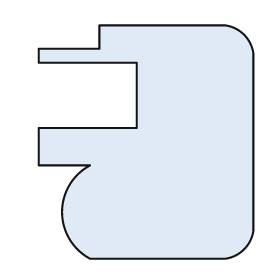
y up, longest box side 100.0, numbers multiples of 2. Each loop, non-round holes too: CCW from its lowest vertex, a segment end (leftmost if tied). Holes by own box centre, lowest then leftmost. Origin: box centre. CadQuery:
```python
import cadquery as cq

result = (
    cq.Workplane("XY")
    .moveTo(-24.0, -50.0)
    .lineTo(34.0, -50.0)
    .threePointArc((42.0, -46.0), (46.0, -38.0))
    .lineTo(46.0, 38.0)
    .threePointArc((42.0, 46.0), (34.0, 50.0))
    .lineTo(-20.0, 50.0)
    .lineTo(-20.0, 40.0)
    .lineTo(-46.0, 40.0)
    .lineTo(-46.0, 34.0)
    .lineTo(-4.0, 34.0)
    .lineTo(-4.0, 6.0)
    .lineTo(-46.0, 6.0)
    .lineTo(-46.0, -10.0)
    .lineTo(-24.0, -10.0)
    .threePointArc((-36.0, -30.0), (-24.0, -50.0))
    .close()
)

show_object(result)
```